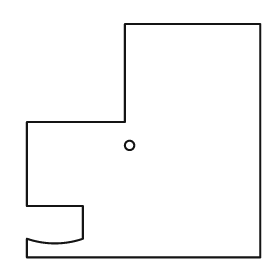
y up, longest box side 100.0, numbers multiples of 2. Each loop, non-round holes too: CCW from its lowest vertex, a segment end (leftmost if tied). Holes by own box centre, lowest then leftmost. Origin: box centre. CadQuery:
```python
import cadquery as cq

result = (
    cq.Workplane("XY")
    .moveTo(-50.0, -50.0)
    .lineTo(50.0, -50.0)
    .lineTo(50.0, 50.0)
    .lineTo(-8.0, 50.0)
    .lineTo(-8.0, 8.0)
    .lineTo(-50.0, 8.0)
    .lineTo(-50.0, -28.0)
    .lineTo(-26.0, -28.0)
    .lineTo(-26.0, -42.0)
    .threePointArc((-38.0, -44.0), (-50.0, -42.0))
    .close()
    .moveTo(-6.0, -2.0)
    .circle(2.0)
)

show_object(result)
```